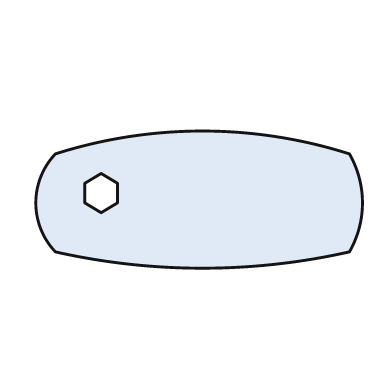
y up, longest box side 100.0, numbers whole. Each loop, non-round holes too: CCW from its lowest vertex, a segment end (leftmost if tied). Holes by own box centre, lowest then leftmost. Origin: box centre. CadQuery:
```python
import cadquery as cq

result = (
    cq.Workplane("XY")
    .moveTo(-44.0, -16.0)
    .threePointArc((1.0, -21.0), (46.0, -16.0))
    .threePointArc((50.0, -1.0), (46.0, 14.0))
    .threePointArc((1.0, 21.0), (-44.0, 14.0))
    .threePointArc((-50.0, -1.0), (-44.0, -16.0))
    .close()
    .moveTo(-30.0, -4.0)
    .lineTo(-25.0, -1.0)
    .lineTo(-25.0, 5.0)
    .lineTo(-30.0, 8.0)
    .lineTo(-35.0, 5.0)
    .lineTo(-35.0, -1.0)
    .close()
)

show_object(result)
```